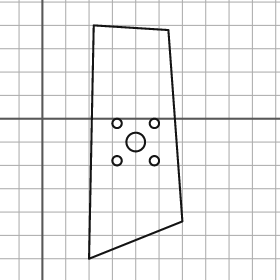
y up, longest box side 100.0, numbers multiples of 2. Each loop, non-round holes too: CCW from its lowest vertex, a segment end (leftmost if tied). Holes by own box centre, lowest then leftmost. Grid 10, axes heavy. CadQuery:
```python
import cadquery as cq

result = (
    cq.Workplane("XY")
    .moveTo(20.0, -60.0)
    .lineTo(60.0, -44.0)
    .lineTo(54.0, 38.0)
    .lineTo(22.0, 40.0)
    .close()
    .moveTo(32.0, -18.0)
    .circle(2.0)
    .moveTo(48.0, -18.0)
    .circle(2.0)
    .moveTo(40.0, -10.0)
    .circle(4.0)
    .moveTo(32.0, -2.0)
    .circle(2.0)
    .moveTo(48.0, -2.0)
    .circle(2.0)
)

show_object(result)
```